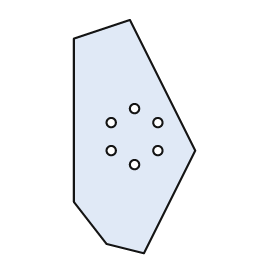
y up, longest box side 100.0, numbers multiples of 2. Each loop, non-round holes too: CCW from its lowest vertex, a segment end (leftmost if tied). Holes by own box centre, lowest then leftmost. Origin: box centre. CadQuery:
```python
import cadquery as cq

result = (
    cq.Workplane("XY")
    .moveTo(4.0, -50.0)
    .lineTo(26.0, -6.0)
    .lineTo(-2.0, 50.0)
    .lineTo(-26.0, 42.0)
    .lineTo(-26.0, -28.0)
    .lineTo(-12.0, -46.0)
    .close()
    .moveTo(0.0, -12.0)
    .circle(2.0)
    .moveTo(-10.0, -6.0)
    .circle(2.0)
    .moveTo(10.0, -6.0)
    .circle(2.0)
    .moveTo(-10.0, 6.0)
    .circle(2.0)
    .moveTo(10.0, 6.0)
    .circle(2.0)
    .moveTo(0.0, 12.0)
    .circle(2.0)
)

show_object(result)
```